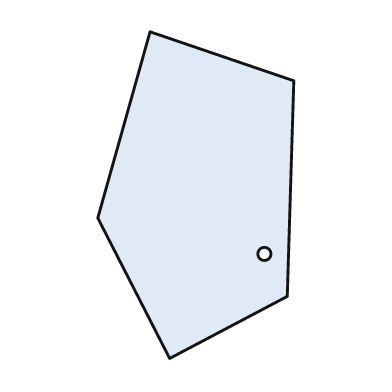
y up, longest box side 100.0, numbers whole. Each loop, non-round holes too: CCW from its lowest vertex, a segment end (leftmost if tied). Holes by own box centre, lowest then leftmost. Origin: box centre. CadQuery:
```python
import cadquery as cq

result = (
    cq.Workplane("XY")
    .moveTo(-8.0, -50.0)
    .lineTo(28.0, -31.0)
    .lineTo(30.0, 35.0)
    .lineTo(-14.0, 50.0)
    .lineTo(-30.0, -7.0)
    .close()
    .moveTo(21.0, -18.0)
    .circle(2.0)
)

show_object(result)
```